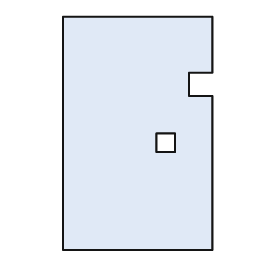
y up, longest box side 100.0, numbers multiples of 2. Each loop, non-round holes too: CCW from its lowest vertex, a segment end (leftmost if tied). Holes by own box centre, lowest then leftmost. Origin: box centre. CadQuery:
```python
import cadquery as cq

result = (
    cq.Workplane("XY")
    .moveTo(-32.0, -50.0)
    .lineTo(32.0, -50.0)
    .lineTo(32.0, 16.0)
    .lineTo(22.0, 16.0)
    .lineTo(22.0, 26.0)
    .lineTo(32.0, 26.0)
    .lineTo(32.0, 50.0)
    .lineTo(-32.0, 50.0)
    .close()
    .moveTo(8.0, -8.0)
    .lineTo(16.0, -8.0)
    .lineTo(16.0, 0.0)
    .lineTo(8.0, 0.0)
    .close()
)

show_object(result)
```